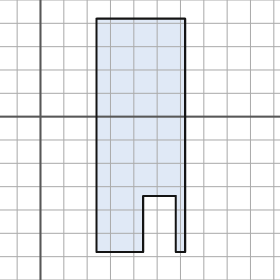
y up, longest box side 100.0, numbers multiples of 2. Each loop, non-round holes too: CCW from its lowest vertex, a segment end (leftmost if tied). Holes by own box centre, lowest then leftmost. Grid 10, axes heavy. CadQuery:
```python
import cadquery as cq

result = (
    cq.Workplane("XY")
    .moveTo(24.0, -58.0)
    .lineTo(44.0, -58.0)
    .lineTo(44.0, -34.0)
    .lineTo(58.0, -34.0)
    .lineTo(58.0, -58.0)
    .lineTo(62.0, -58.0)
    .lineTo(62.0, 42.0)
    .lineTo(24.0, 42.0)
    .close()
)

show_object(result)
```